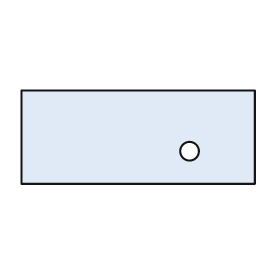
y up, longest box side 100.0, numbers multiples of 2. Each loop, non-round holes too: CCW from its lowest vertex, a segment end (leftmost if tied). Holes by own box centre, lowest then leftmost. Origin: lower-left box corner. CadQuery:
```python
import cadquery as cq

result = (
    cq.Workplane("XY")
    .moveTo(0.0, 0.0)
    .lineTo(100.0, 0.0)
    .lineTo(100.0, 40.0)
    .lineTo(0.0, 40.0)
    .close()
    .moveTo(72.0, 14.0)
    .circle(4.0)
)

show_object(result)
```